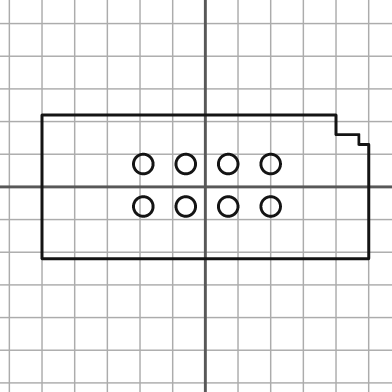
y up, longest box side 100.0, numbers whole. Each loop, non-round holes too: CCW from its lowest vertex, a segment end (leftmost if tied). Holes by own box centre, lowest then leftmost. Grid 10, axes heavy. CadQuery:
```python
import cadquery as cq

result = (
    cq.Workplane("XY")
    .moveTo(-50.0, -22.0)
    .lineTo(50.0, -22.0)
    .lineTo(50.0, 13.0)
    .lineTo(47.0, 13.0)
    .lineTo(47.0, 16.0)
    .lineTo(40.0, 16.0)
    .lineTo(40.0, 22.0)
    .lineTo(-50.0, 22.0)
    .close()
    .moveTo(-19.0, -6.0)
    .circle(3.0)
    .moveTo(-6.0, -6.0)
    .circle(3.0)
    .moveTo(7.0, -6.0)
    .circle(3.0)
    .moveTo(20.0, -6.0)
    .circle(3.0)
    .moveTo(-19.0, 7.0)
    .circle(3.0)
    .moveTo(-6.0, 7.0)
    .circle(3.0)
    .moveTo(7.0, 7.0)
    .circle(3.0)
    .moveTo(20.0, 7.0)
    .circle(3.0)
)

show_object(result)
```